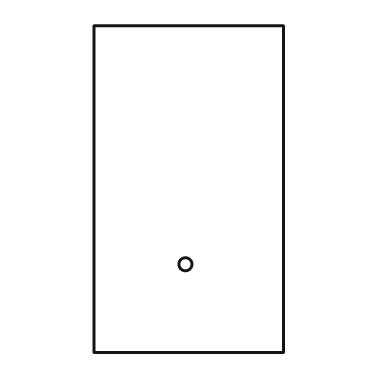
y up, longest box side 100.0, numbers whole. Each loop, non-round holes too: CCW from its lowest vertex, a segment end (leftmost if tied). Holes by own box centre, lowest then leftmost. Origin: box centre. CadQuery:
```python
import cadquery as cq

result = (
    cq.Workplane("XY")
    .moveTo(-29.0, -50.0)
    .lineTo(29.0, -50.0)
    .lineTo(29.0, 50.0)
    .lineTo(-29.0, 50.0)
    .close()
    .moveTo(-1.0, -23.0)
    .circle(2.0)
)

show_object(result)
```